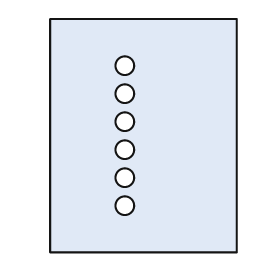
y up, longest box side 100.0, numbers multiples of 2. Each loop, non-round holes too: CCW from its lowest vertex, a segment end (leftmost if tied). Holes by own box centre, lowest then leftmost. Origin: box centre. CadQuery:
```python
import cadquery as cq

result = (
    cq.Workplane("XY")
    .moveTo(-40.0, -50.0)
    .lineTo(40.0, -50.0)
    .lineTo(40.0, 50.0)
    .lineTo(-40.0, 50.0)
    .close()
    .moveTo(-8.0, -30.0)
    .circle(4.0)
    .moveTo(-8.0, -18.0)
    .circle(4.0)
    .moveTo(-8.0, -6.0)
    .circle(4.0)
    .moveTo(-8.0, 6.0)
    .circle(4.0)
    .moveTo(-8.0, 18.0)
    .circle(4.0)
    .moveTo(-8.0, 30.0)
    .circle(4.0)
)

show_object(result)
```